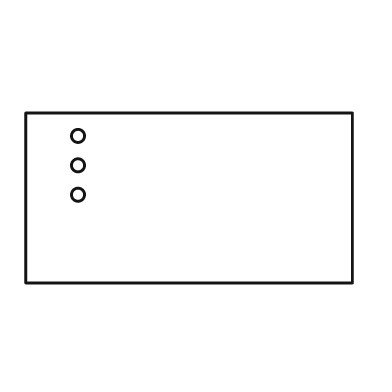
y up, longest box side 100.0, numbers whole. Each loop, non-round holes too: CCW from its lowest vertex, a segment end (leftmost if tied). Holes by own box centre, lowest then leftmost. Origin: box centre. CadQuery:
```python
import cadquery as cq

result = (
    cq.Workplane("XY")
    .moveTo(-50.0, -26.0)
    .lineTo(50.0, -26.0)
    .lineTo(50.0, 26.0)
    .lineTo(-50.0, 26.0)
    .close()
    .moveTo(-34.0, 1.0)
    .circle(2.0)
    .moveTo(-34.0, 10.0)
    .circle(2.0)
    .moveTo(-34.0, 19.0)
    .circle(2.0)
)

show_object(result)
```